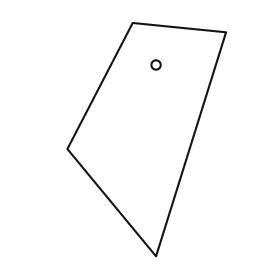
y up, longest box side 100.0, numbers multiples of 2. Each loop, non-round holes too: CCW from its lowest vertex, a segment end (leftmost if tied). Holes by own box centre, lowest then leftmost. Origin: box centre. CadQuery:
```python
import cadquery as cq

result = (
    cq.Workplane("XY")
    .moveTo(4.0, -50.0)
    .lineTo(34.0, 46.0)
    .lineTo(-6.0, 50.0)
    .lineTo(-34.0, -4.0)
    .close()
    .moveTo(4.0, 32.0)
    .circle(2.0)
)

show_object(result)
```